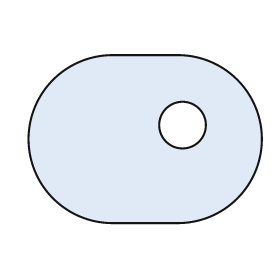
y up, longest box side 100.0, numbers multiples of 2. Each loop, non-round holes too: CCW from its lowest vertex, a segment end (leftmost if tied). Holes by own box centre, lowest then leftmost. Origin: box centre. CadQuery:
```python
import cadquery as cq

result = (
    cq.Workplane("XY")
    .moveTo(-14.0, -36.0)
    .lineTo(14.0, -36.0)
    .threePointArc((50.0, 0.0), (14.0, 36.0))
    .lineTo(-14.0, 36.0)
    .threePointArc((-50.0, 0.0), (-14.0, -36.0))
    .close()
    .moveTo(16.0, 6.0)
    .circle(10.0)
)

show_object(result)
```